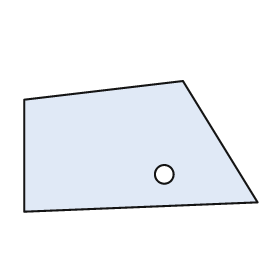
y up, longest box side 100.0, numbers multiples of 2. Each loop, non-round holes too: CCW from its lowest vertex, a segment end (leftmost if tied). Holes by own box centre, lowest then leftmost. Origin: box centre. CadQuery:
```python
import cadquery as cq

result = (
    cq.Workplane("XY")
    .moveTo(-50.0, -28.0)
    .lineTo(50.0, -24.0)
    .lineTo(18.0, 28.0)
    .lineTo(-50.0, 20.0)
    .close()
    .moveTo(10.0, -12.0)
    .circle(4.0)
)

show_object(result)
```